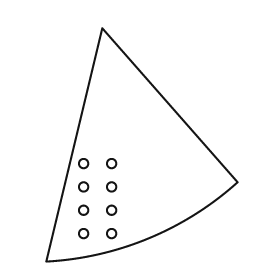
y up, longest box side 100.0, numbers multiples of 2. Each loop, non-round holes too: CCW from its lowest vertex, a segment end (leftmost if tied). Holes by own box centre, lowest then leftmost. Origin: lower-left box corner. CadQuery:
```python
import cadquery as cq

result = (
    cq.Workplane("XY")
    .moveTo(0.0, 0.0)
    .threePointArc((44.0, 10.0), (82.0, 34.0))
    .lineTo(24.0, 100.0)
    .close()
    .moveTo(16.0, 12.0)
    .circle(2.0)
    .moveTo(28.0, 12.0)
    .circle(2.0)
    .moveTo(16.0, 22.0)
    .circle(2.0)
    .moveTo(28.0, 22.0)
    .circle(2.0)
    .moveTo(16.0, 32.0)
    .circle(2.0)
    .moveTo(28.0, 32.0)
    .circle(2.0)
    .moveTo(16.0, 42.0)
    .circle(2.0)
    .moveTo(28.0, 42.0)
    .circle(2.0)
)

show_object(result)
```